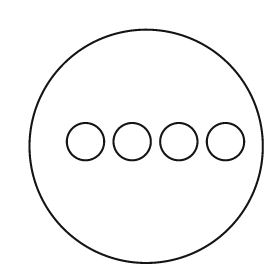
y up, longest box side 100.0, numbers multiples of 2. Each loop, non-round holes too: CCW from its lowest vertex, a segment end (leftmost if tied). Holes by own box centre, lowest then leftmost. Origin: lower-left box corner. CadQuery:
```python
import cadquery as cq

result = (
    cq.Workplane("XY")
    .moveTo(50.0, 50.0)
    .circle(50.0)
    .moveTo(24.0, 52.0)
    .circle(8.0)
    .moveTo(44.0, 52.0)
    .circle(8.0)
    .moveTo(64.0, 52.0)
    .circle(8.0)
    .moveTo(84.0, 52.0)
    .circle(8.0)
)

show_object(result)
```